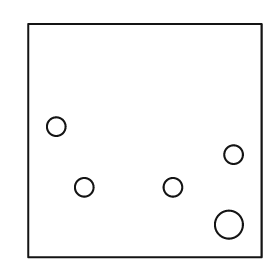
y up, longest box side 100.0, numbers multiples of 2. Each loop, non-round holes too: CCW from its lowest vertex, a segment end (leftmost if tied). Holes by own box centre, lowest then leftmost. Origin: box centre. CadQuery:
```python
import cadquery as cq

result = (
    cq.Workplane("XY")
    .moveTo(-50.0, -50.0)
    .lineTo(50.0, -50.0)
    .lineTo(50.0, 50.0)
    .lineTo(-50.0, 50.0)
    .close()
    .moveTo(36.0, -36.0)
    .circle(6.0)
    .moveTo(-26.0, -20.0)
    .circle(4.0)
    .moveTo(12.0, -20.0)
    .circle(4.0)
    .moveTo(38.0, -6.0)
    .circle(4.0)
    .moveTo(-38.0, 6.0)
    .circle(4.0)
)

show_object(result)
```